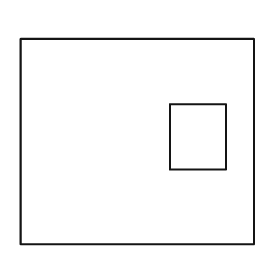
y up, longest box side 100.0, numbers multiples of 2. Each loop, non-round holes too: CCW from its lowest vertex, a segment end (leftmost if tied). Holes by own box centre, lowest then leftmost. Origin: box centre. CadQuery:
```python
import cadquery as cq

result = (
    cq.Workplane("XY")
    .moveTo(-50.0, -44.0)
    .lineTo(50.0, -44.0)
    .lineTo(50.0, 44.0)
    .lineTo(-50.0, 44.0)
    .close()
    .moveTo(14.0, -12.0)
    .lineTo(38.0, -12.0)
    .lineTo(38.0, 16.0)
    .lineTo(14.0, 16.0)
    .close()
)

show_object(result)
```